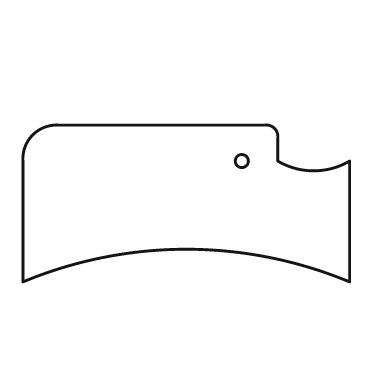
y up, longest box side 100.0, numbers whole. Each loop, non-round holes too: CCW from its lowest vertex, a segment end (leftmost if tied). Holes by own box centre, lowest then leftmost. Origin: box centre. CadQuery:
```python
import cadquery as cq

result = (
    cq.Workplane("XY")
    .moveTo(-50.0, -24.0)
    .threePointArc((0.0, -14.0), (50.0, -24.0))
    .lineTo(50.0, 13.0)
    .threePointArc((39.0, 10.0), (28.0, 13.0))
    .lineTo(28.0, 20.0)
    .threePointArc((27.0, 23.0), (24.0, 24.0))
    .lineTo(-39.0, 24.0)
    .threePointArc((-47.0, 21.0), (-50.0, 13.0))
    .close()
    .moveTo(17.0, 13.0)
    .circle(2.0)
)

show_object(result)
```